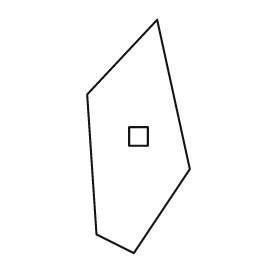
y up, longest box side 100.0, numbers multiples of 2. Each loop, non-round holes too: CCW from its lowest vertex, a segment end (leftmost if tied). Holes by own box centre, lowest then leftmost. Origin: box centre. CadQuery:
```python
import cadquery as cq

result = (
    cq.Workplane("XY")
    .moveTo(-2.0, -50.0)
    .lineTo(22.0, -14.0)
    .lineTo(8.0, 50.0)
    .lineTo(-22.0, 18.0)
    .lineTo(-18.0, -42.0)
    .close()
    .moveTo(-4.0, -4.0)
    .lineTo(4.0, -4.0)
    .lineTo(4.0, 4.0)
    .lineTo(-4.0, 4.0)
    .close()
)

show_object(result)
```